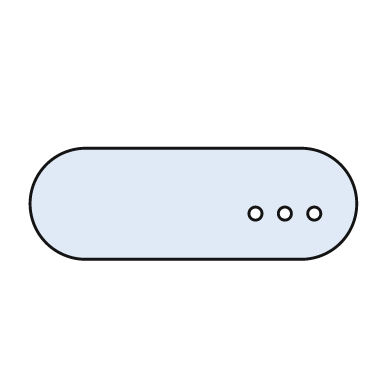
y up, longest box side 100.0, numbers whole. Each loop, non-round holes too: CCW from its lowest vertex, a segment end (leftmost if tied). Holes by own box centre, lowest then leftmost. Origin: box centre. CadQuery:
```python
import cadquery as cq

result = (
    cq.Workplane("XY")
    .moveTo(-33.0, -17.0)
    .lineTo(33.0, -17.0)
    .threePointArc((50.0, 0.0), (33.0, 17.0))
    .lineTo(-33.0, 17.0)
    .threePointArc((-50.0, 0.0), (-33.0, -17.0))
    .close()
    .moveTo(19.0, -3.0)
    .circle(2.0)
    .moveTo(28.0, -3.0)
    .circle(2.0)
    .moveTo(37.0, -3.0)
    .circle(2.0)
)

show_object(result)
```